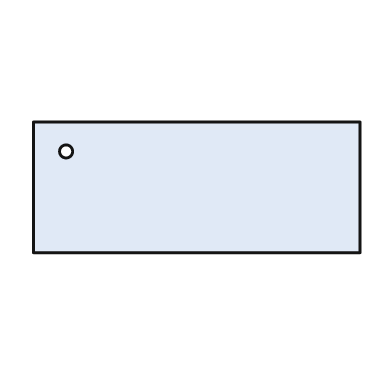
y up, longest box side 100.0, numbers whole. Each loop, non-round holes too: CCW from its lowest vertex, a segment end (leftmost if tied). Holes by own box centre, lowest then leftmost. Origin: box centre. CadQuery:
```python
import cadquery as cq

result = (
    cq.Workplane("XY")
    .moveTo(-50.0, -20.0)
    .lineTo(50.0, -20.0)
    .lineTo(50.0, 20.0)
    .lineTo(-50.0, 20.0)
    .close()
    .moveTo(-40.0, 11.0)
    .circle(2.0)
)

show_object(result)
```